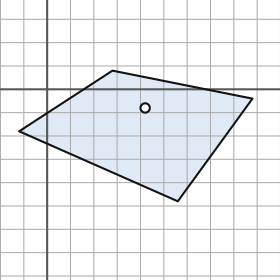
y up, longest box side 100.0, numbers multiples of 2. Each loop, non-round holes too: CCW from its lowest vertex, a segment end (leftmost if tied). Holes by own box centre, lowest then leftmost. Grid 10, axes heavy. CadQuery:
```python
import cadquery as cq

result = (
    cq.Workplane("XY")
    .moveTo(56.0, -48.0)
    .lineTo(88.0, -4.0)
    .lineTo(28.0, 8.0)
    .lineTo(-12.0, -18.0)
    .close()
    .moveTo(42.0, -8.0)
    .circle(2.0)
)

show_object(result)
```